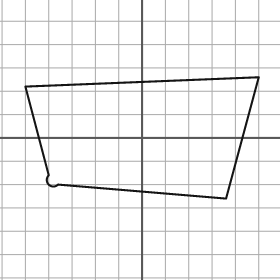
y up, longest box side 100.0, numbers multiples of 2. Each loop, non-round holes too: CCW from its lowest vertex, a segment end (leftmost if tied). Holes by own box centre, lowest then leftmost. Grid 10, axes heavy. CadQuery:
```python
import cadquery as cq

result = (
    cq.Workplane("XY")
    .moveTo(36.0, -26.0)
    .lineTo(50.0, 26.0)
    .lineTo(-50.0, 22.0)
    .lineTo(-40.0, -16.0)
    .threePointArc((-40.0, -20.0), (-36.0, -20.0))
    .close()
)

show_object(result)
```